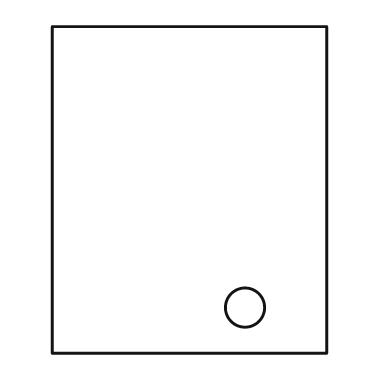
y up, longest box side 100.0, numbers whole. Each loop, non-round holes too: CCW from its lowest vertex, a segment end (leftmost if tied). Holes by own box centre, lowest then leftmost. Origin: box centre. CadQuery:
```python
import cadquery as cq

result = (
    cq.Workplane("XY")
    .moveTo(-42.0, -50.0)
    .lineTo(42.0, -50.0)
    .lineTo(42.0, 50.0)
    .lineTo(-42.0, 50.0)
    .close()
    .moveTo(17.0, -36.0)
    .circle(6.0)
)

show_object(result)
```